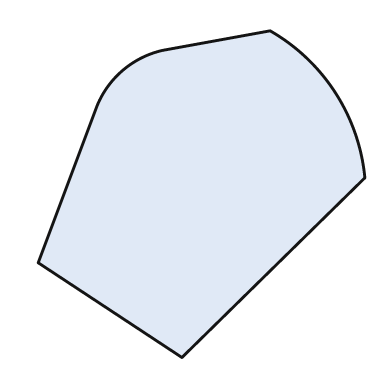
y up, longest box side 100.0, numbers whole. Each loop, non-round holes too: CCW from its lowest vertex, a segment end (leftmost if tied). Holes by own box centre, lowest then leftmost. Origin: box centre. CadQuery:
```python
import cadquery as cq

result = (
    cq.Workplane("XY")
    .moveTo(-6.0, -50.0)
    .lineTo(50.0, 5.0)
    .threePointArc((41.0, 31.0), (21.0, 50.0))
    .lineTo(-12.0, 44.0)
    .threePointArc((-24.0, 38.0), (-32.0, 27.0))
    .lineTo(-50.0, -21.0)
    .close()
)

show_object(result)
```